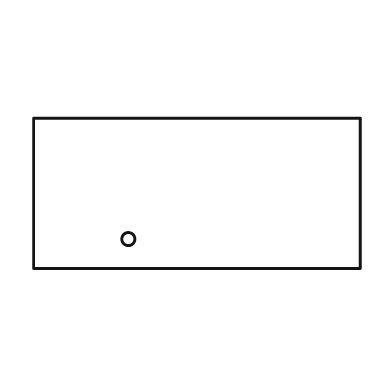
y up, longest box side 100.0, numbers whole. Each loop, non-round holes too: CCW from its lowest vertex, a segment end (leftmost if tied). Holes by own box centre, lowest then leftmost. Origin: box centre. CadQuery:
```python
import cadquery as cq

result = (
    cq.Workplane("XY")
    .moveTo(-50.0, -23.0)
    .lineTo(50.0, -23.0)
    .lineTo(50.0, 23.0)
    .lineTo(-50.0, 23.0)
    .close()
    .moveTo(-21.0, -14.0)
    .circle(2.0)
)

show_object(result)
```